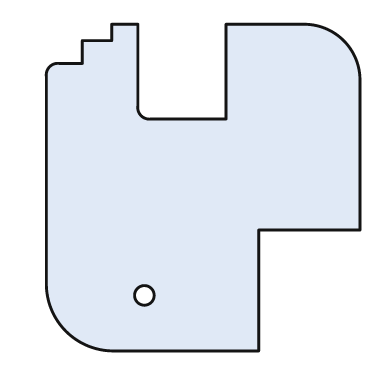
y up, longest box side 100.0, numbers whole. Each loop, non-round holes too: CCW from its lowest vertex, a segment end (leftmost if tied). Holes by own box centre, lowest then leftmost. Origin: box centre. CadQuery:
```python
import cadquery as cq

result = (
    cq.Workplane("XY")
    .moveTo(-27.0, -50.0)
    .lineTo(17.0, -50.0)
    .lineTo(17.0, -13.0)
    .lineTo(48.0, -13.0)
    .lineTo(48.0, 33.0)
    .threePointArc((43.0, 45.0), (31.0, 50.0))
    .lineTo(7.0, 50.0)
    .lineTo(7.0, 21.0)
    .lineTo(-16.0, 21.0)
    .threePointArc((-19.0, 22.0), (-20.0, 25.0))
    .lineTo(-20.0, 50.0)
    .lineTo(-28.0, 50.0)
    .lineTo(-28.0, 45.0)
    .lineTo(-37.0, 45.0)
    .lineTo(-37.0, 38.0)
    .lineTo(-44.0, 38.0)
    .threePointArc((-47.0, 37.0), (-48.0, 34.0))
    .lineTo(-48.0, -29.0)
    .threePointArc((-42.0, -44.0), (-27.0, -50.0))
    .close()
    .moveTo(-18.0, -33.0)
    .circle(3.0)
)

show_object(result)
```